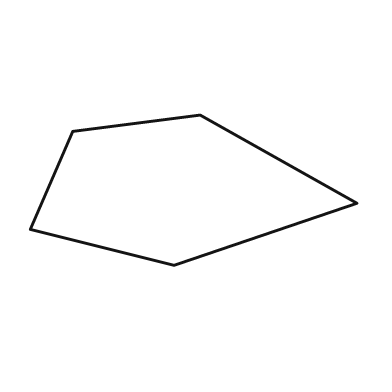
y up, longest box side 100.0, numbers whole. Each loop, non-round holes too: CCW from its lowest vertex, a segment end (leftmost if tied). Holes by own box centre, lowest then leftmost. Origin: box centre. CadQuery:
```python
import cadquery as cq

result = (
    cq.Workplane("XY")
    .moveTo(-6.0, -23.0)
    .lineTo(50.0, -4.0)
    .lineTo(2.0, 23.0)
    .lineTo(-37.0, 18.0)
    .lineTo(-50.0, -12.0)
    .close()
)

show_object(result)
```